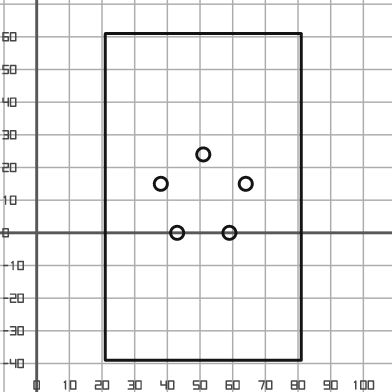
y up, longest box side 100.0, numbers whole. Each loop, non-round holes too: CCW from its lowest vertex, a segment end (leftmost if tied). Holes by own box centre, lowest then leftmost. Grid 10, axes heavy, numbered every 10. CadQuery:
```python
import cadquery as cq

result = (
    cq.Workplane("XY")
    .moveTo(21.0, -39.0)
    .lineTo(81.0, -39.0)
    .lineTo(81.0, 61.0)
    .lineTo(21.0, 61.0)
    .close()
    .moveTo(43.0, 0.0)
    .circle(2.0)
    .moveTo(59.0, 0.0)
    .circle(2.0)
    .moveTo(38.0, 15.0)
    .circle(2.0)
    .moveTo(64.0, 15.0)
    .circle(2.0)
    .moveTo(51.0, 24.0)
    .circle(2.0)
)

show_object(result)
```